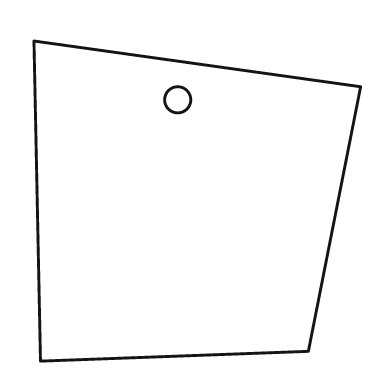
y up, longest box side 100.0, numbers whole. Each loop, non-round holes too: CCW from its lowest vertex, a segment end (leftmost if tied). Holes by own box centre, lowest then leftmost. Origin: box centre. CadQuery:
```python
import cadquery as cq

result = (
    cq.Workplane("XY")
    .moveTo(-48.0, -49.0)
    .lineTo(34.0, -46.0)
    .lineTo(50.0, 35.0)
    .lineTo(-50.0, 49.0)
    .close()
    .moveTo(-6.0, 31.0)
    .circle(4.0)
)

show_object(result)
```